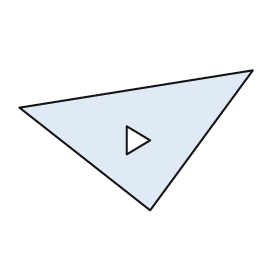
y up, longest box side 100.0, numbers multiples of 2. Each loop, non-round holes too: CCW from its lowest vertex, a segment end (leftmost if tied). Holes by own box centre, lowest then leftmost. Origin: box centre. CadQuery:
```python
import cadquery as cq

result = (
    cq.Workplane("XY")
    .moveTo(6.0, -30.0)
    .lineTo(50.0, 30.0)
    .lineTo(-50.0, 14.0)
    .close()
    .moveTo(-4.0, -6.0)
    .lineTo(6.0, 0.0)
    .lineTo(-4.0, 6.0)
    .close()
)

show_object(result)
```